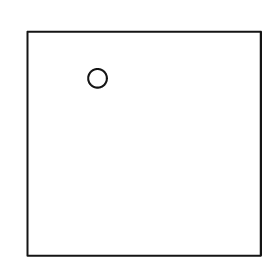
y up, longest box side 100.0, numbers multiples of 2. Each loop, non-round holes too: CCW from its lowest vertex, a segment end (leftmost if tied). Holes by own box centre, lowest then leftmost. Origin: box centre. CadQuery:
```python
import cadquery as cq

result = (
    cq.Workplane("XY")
    .moveTo(-50.0, -48.0)
    .lineTo(50.0, -48.0)
    .lineTo(50.0, 48.0)
    .lineTo(-50.0, 48.0)
    .close()
    .moveTo(-20.0, 28.0)
    .circle(4.0)
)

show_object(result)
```